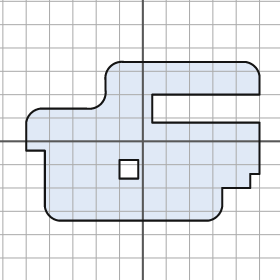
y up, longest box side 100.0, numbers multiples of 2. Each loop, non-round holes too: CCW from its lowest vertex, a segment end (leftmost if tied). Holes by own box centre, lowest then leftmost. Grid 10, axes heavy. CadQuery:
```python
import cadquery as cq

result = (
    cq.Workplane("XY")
    .moveTo(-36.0, -34.0)
    .lineTo(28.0, -34.0)
    .threePointArc((32.0, -32.0), (34.0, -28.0))
    .lineTo(34.0, -20.0)
    .lineTo(46.0, -20.0)
    .lineTo(46.0, -14.0)
    .lineTo(50.0, -14.0)
    .lineTo(50.0, 8.0)
    .lineTo(4.0, 8.0)
    .lineTo(4.0, 20.0)
    .lineTo(50.0, 20.0)
    .lineTo(50.0, 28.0)
    .threePointArc((48.0, 32.0), (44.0, 34.0))
    .lineTo(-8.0, 34.0)
    .threePointArc((-14.0, 32.0), (-16.0, 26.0))
    .lineTo(-16.0, 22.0)
    .threePointArc((-18.0, 16.0), (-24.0, 14.0))
    .lineTo(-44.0, 14.0)
    .threePointArc((-48.0, 12.0), (-50.0, 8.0))
    .lineTo(-50.0, -4.0)
    .lineTo(-42.0, -4.0)
    .lineTo(-42.0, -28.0)
    .threePointArc((-40.0, -32.0), (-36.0, -34.0))
    .close()
    .moveTo(-10.0, -16.0)
    .lineTo(-2.0, -16.0)
    .lineTo(-2.0, -8.0)
    .lineTo(-10.0, -8.0)
    .close()
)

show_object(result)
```